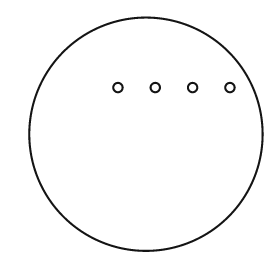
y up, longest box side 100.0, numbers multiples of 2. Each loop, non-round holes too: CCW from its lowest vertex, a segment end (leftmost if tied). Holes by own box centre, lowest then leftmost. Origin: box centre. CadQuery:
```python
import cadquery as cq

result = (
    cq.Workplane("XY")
    .moveTo(0.0, 0.0)
    .circle(50.0)
    .moveTo(-12.0, 20.0)
    .circle(2.0)
    .moveTo(4.0, 20.0)
    .circle(2.0)
    .moveTo(20.0, 20.0)
    .circle(2.0)
    .moveTo(36.0, 20.0)
    .circle(2.0)
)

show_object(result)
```